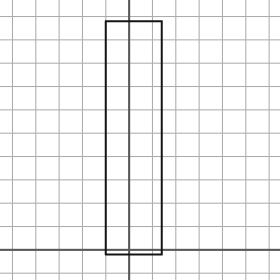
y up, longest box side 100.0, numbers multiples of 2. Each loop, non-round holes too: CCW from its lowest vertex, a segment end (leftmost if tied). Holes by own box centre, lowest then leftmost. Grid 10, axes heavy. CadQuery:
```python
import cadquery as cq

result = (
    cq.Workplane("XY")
    .moveTo(-10.0, -2.0)
    .lineTo(14.0, -2.0)
    .lineTo(14.0, 98.0)
    .lineTo(-10.0, 98.0)
    .close()
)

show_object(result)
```